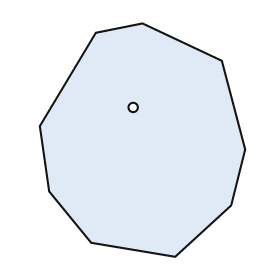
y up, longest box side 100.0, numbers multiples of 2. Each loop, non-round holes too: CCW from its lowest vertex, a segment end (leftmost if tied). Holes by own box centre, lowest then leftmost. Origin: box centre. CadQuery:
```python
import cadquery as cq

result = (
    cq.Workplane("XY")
    .moveTo(14.0, -50.0)
    .lineTo(38.0, -28.0)
    .lineTo(44.0, -4.0)
    .lineTo(34.0, 34.0)
    .lineTo(0.0, 50.0)
    .lineTo(-20.0, 46.0)
    .lineTo(-44.0, 6.0)
    .lineTo(-40.0, -22.0)
    .lineTo(-22.0, -44.0)
    .close()
    .moveTo(-4.0, 14.0)
    .circle(2.0)
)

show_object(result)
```